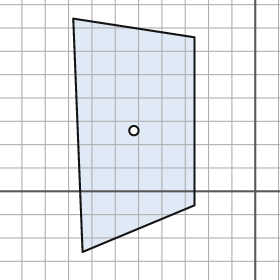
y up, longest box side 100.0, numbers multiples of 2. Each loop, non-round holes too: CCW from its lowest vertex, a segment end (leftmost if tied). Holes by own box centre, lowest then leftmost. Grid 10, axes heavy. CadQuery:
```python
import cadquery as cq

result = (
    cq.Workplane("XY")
    .moveTo(-74.0, -26.0)
    .lineTo(-26.0, -6.0)
    .lineTo(-26.0, 66.0)
    .lineTo(-78.0, 74.0)
    .close()
    .moveTo(-52.0, 26.0)
    .circle(2.0)
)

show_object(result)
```